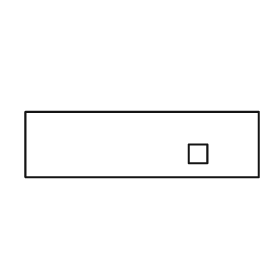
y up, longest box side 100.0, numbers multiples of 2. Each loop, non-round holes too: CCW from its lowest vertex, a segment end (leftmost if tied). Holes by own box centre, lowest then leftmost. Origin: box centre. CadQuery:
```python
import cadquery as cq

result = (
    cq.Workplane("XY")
    .moveTo(-50.0, -14.0)
    .lineTo(50.0, -14.0)
    .lineTo(50.0, 14.0)
    .lineTo(-50.0, 14.0)
    .close()
    .moveTo(20.0, -8.0)
    .lineTo(28.0, -8.0)
    .lineTo(28.0, 0.0)
    .lineTo(20.0, 0.0)
    .close()
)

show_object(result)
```